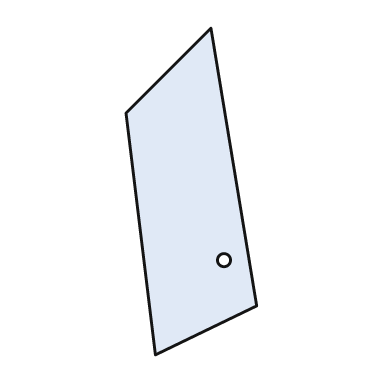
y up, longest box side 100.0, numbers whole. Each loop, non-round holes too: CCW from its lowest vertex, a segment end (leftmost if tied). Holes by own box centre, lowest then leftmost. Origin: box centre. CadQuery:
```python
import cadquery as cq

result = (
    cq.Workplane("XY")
    .moveTo(-11.0, -50.0)
    .lineTo(20.0, -35.0)
    .lineTo(6.0, 50.0)
    .lineTo(-20.0, 24.0)
    .close()
    .moveTo(10.0, -21.0)
    .circle(2.0)
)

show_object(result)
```